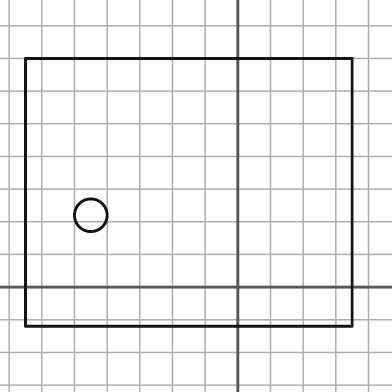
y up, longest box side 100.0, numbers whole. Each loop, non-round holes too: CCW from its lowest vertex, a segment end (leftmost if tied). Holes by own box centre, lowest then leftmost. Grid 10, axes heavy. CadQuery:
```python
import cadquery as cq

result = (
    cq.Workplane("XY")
    .moveTo(-65.0, -12.0)
    .lineTo(35.0, -12.0)
    .lineTo(35.0, 70.0)
    .lineTo(-65.0, 70.0)
    .close()
    .moveTo(-45.0, 22.0)
    .circle(5.0)
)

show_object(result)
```